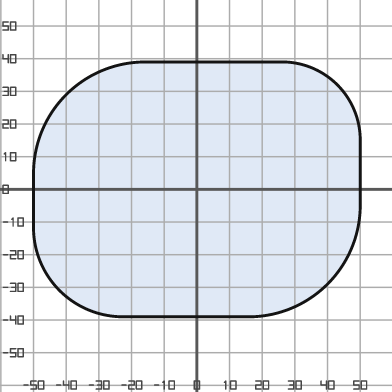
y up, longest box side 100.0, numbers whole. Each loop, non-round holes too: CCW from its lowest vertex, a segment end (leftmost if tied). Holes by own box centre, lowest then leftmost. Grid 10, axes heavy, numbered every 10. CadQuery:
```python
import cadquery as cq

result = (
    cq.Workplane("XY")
    .moveTo(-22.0, -39.0)
    .lineTo(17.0, -39.0)
    .threePointArc((40.0, -29.0), (50.0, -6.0))
    .lineTo(50.0, 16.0)
    .threePointArc((43.0, 32.0), (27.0, 39.0))
    .lineTo(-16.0, 39.0)
    .threePointArc((-40.0, 29.0), (-50.0, 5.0))
    .lineTo(-50.0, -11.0)
    .threePointArc((-42.0, -31.0), (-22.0, -39.0))
    .close()
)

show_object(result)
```